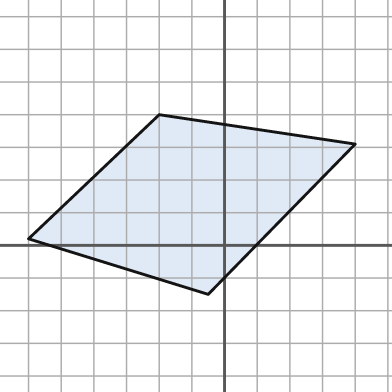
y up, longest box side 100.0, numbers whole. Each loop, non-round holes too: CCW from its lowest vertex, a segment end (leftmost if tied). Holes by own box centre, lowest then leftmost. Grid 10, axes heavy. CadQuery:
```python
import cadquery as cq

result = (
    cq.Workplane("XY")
    .moveTo(-5.0, -15.0)
    .lineTo(40.0, 31.0)
    .lineTo(-20.0, 40.0)
    .lineTo(-60.0, 2.0)
    .close()
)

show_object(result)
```